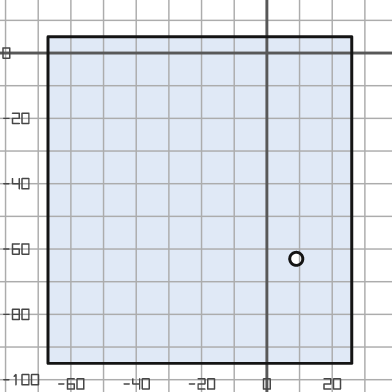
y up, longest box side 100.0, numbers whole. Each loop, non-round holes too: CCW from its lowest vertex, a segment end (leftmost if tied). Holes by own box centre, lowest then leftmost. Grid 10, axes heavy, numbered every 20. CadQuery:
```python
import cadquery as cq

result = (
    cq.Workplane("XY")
    .moveTo(-67.0, -95.0)
    .lineTo(26.0, -95.0)
    .lineTo(26.0, 5.0)
    .lineTo(-67.0, 5.0)
    .close()
    .moveTo(9.0, -63.0)
    .circle(2.0)
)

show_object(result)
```